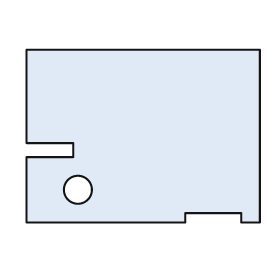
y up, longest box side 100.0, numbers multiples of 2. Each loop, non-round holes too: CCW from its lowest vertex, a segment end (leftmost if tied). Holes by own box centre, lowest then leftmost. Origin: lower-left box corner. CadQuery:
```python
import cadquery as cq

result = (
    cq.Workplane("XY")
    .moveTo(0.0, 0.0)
    .lineTo(68.0, 0.0)
    .lineTo(68.0, 4.0)
    .lineTo(92.0, 4.0)
    .lineTo(92.0, 0.0)
    .lineTo(100.0, 0.0)
    .lineTo(100.0, 74.0)
    .lineTo(0.0, 74.0)
    .lineTo(0.0, 34.0)
    .lineTo(20.0, 34.0)
    .lineTo(20.0, 28.0)
    .lineTo(0.0, 28.0)
    .close()
    .moveTo(22.0, 14.0)
    .circle(6.0)
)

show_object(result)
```